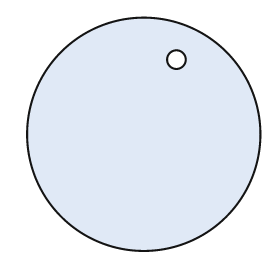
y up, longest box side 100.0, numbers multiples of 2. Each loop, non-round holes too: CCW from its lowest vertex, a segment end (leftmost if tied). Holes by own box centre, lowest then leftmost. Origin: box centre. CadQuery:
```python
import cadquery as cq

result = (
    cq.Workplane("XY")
    .moveTo(0.0, 0.0)
    .circle(50.0)
    .moveTo(14.0, 32.0)
    .circle(4.0)
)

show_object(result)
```